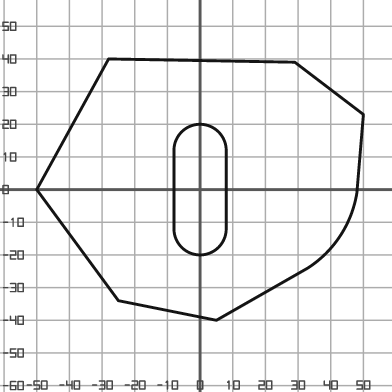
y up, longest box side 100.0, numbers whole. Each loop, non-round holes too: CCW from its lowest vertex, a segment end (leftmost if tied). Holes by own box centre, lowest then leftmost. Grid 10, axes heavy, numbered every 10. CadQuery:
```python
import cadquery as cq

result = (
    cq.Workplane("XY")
    .moveTo(5.0, -40.0)
    .lineTo(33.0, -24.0)
    .threePointArc((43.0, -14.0), (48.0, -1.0))
    .lineTo(50.0, 23.0)
    .lineTo(29.0, 39.0)
    .lineTo(-28.0, 40.0)
    .lineTo(-50.0, 0.0)
    .lineTo(-25.0, -34.0)
    .close()
    .moveTo(-8.0, -12.0)
    .threePointArc((0.0, -20.0), (8.0, -12.0))
    .lineTo(8.0, 12.0)
    .threePointArc((0.0, 20.0), (-8.0, 12.0))
    .close()
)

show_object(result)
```